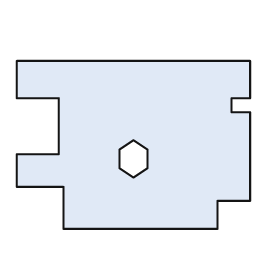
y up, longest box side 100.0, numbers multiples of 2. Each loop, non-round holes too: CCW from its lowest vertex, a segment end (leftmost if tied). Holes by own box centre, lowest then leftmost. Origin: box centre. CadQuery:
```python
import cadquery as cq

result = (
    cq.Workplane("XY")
    .moveTo(-30.0, -36.0)
    .lineTo(36.0, -36.0)
    .lineTo(36.0, -24.0)
    .lineTo(50.0, -24.0)
    .lineTo(50.0, 14.0)
    .lineTo(42.0, 14.0)
    .lineTo(42.0, 20.0)
    .lineTo(50.0, 20.0)
    .lineTo(50.0, 36.0)
    .lineTo(-50.0, 36.0)
    .lineTo(-50.0, 20.0)
    .lineTo(-32.0, 20.0)
    .lineTo(-32.0, -4.0)
    .lineTo(-50.0, -4.0)
    .lineTo(-50.0, -18.0)
    .lineTo(-30.0, -18.0)
    .close()
    .moveTo(0.0, -14.0)
    .lineTo(6.0, -10.0)
    .lineTo(6.0, -2.0)
    .lineTo(0.0, 2.0)
    .lineTo(-6.0, -2.0)
    .lineTo(-6.0, -10.0)
    .close()
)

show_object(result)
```